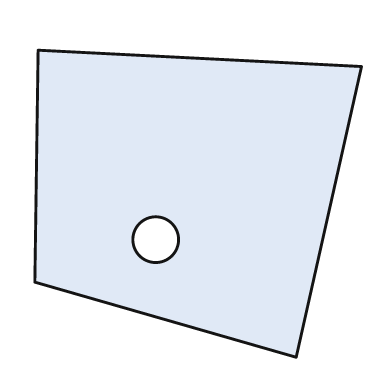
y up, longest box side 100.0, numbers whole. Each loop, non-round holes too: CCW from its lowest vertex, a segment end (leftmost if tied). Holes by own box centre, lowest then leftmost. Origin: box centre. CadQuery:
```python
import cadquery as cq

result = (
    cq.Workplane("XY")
    .moveTo(30.0, -47.0)
    .lineTo(50.0, 42.0)
    .lineTo(-49.0, 47.0)
    .lineTo(-50.0, -24.0)
    .close()
    .moveTo(-13.0, -11.0)
    .circle(7.0)
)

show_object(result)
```